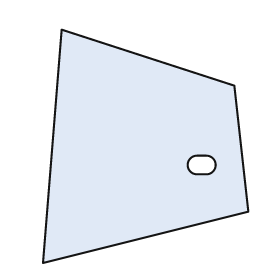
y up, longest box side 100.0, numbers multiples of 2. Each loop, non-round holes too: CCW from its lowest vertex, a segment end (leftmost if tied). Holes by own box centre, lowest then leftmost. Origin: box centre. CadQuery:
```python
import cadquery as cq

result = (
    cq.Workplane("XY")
    .moveTo(-44.0, -50.0)
    .lineTo(44.0, -28.0)
    .lineTo(38.0, 26.0)
    .lineTo(-36.0, 50.0)
    .close()
    .moveTo(22.0, -12.0)
    .lineTo(26.0, -12.0)
    .threePointArc((30.0, -8.0), (26.0, -4.0))
    .lineTo(22.0, -4.0)
    .threePointArc((18.0, -8.0), (22.0, -12.0))
    .close()
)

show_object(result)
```